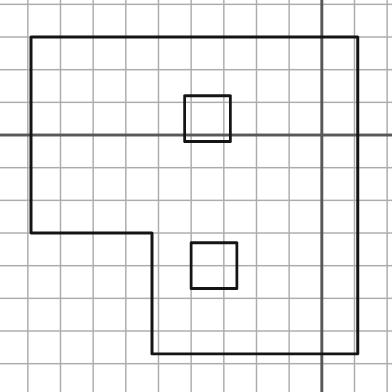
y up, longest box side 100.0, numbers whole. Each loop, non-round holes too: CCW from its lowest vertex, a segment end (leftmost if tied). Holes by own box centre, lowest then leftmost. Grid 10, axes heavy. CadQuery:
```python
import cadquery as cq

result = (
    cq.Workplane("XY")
    .moveTo(-52.0, -67.0)
    .lineTo(11.0, -67.0)
    .lineTo(11.0, 30.0)
    .lineTo(-89.0, 30.0)
    .lineTo(-89.0, -30.0)
    .lineTo(-52.0, -30.0)
    .close()
    .moveTo(-40.0, -47.0)
    .lineTo(-26.0, -47.0)
    .lineTo(-26.0, -33.0)
    .lineTo(-40.0, -33.0)
    .close()
    .moveTo(-42.0, -2.0)
    .lineTo(-28.0, -2.0)
    .lineTo(-28.0, 12.0)
    .lineTo(-42.0, 12.0)
    .close()
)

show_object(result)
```